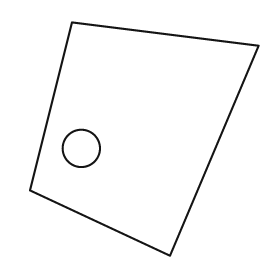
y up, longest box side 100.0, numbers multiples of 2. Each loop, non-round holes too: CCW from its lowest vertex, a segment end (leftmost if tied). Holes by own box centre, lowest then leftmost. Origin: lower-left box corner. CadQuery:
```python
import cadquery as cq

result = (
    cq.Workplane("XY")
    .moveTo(60.0, 0.0)
    .lineTo(98.0, 90.0)
    .lineTo(18.0, 100.0)
    .lineTo(0.0, 28.0)
    .close()
    .moveTo(22.0, 46.0)
    .circle(8.0)
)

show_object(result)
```